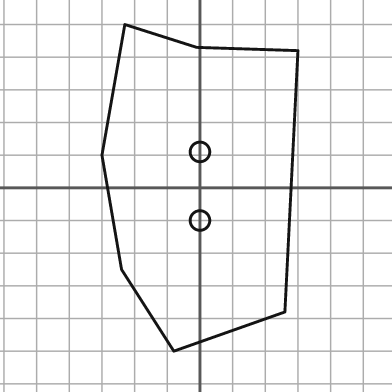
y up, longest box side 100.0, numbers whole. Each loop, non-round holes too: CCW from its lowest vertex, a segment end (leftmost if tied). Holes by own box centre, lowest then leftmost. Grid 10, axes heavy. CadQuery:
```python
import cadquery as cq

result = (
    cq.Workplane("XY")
    .moveTo(-8.0, -50.0)
    .lineTo(26.0, -38.0)
    .lineTo(30.0, 42.0)
    .lineTo(-1.0, 43.0)
    .lineTo(-23.0, 50.0)
    .lineTo(-30.0, 10.0)
    .lineTo(-24.0, -25.0)
    .close()
    .moveTo(0.0, -10.0)
    .circle(3.0)
    .moveTo(0.0, 11.0)
    .circle(3.0)
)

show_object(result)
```